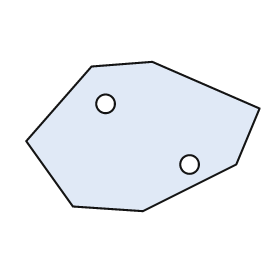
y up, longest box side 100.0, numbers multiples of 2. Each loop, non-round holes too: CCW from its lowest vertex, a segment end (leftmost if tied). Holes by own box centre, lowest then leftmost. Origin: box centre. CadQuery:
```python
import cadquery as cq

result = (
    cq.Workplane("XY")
    .moveTo(0.0, -32.0)
    .lineTo(40.0, -12.0)
    .lineTo(50.0, 12.0)
    .lineTo(4.0, 32.0)
    .lineTo(-22.0, 30.0)
    .lineTo(-50.0, -2.0)
    .lineTo(-30.0, -30.0)
    .close()
    .moveTo(20.0, -12.0)
    .circle(4.0)
    .moveTo(-16.0, 14.0)
    .circle(4.0)
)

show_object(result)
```